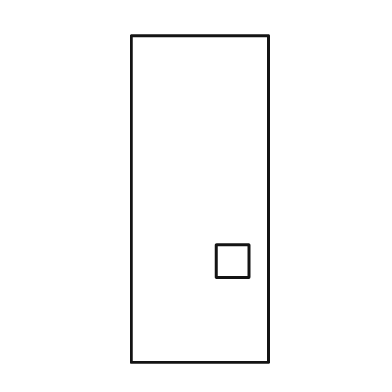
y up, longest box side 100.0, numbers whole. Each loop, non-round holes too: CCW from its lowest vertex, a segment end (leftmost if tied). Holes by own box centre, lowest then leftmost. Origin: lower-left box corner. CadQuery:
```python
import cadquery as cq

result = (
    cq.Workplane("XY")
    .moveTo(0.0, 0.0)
    .lineTo(42.0, 0.0)
    .lineTo(42.0, 100.0)
    .lineTo(0.0, 100.0)
    .close()
    .moveTo(26.0, 26.0)
    .lineTo(36.0, 26.0)
    .lineTo(36.0, 36.0)
    .lineTo(26.0, 36.0)
    .close()
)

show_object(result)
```